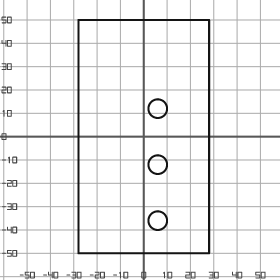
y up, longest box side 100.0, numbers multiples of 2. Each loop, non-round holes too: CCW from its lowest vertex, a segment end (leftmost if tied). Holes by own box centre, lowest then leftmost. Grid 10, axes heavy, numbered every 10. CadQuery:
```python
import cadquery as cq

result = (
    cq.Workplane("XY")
    .moveTo(-28.0, -50.0)
    .lineTo(28.0, -50.0)
    .lineTo(28.0, 50.0)
    .lineTo(-28.0, 50.0)
    .close()
    .moveTo(6.0, -36.0)
    .circle(4.0)
    .moveTo(6.0, -12.0)
    .circle(4.0)
    .moveTo(6.0, 12.0)
    .circle(4.0)
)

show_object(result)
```